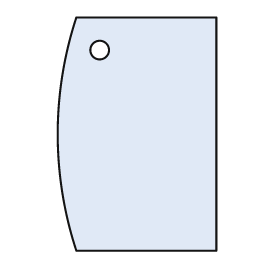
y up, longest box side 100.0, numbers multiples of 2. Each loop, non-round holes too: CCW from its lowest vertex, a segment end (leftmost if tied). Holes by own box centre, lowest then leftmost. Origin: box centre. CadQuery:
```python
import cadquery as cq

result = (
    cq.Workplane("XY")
    .moveTo(-26.0, -50.0)
    .lineTo(34.0, -50.0)
    .lineTo(34.0, 50.0)
    .lineTo(-26.0, 50.0)
    .threePointArc((-34.0, 0.0), (-26.0, -50.0))
    .close()
    .moveTo(-16.0, 36.0)
    .circle(4.0)
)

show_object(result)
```